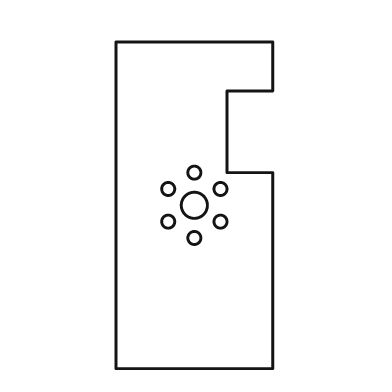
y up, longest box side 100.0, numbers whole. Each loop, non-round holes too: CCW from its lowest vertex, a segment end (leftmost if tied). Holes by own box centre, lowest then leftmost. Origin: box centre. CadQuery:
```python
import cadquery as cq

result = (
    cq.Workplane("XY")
    .moveTo(-24.0, -50.0)
    .lineTo(24.0, -50.0)
    .lineTo(24.0, 10.0)
    .lineTo(10.0, 10.0)
    .lineTo(10.0, 35.0)
    .lineTo(24.0, 35.0)
    .lineTo(24.0, 50.0)
    .lineTo(-24.0, 50.0)
    .close()
    .moveTo(0.0, -10.0)
    .circle(2.0)
    .moveTo(-8.0, -5.0)
    .circle(2.0)
    .moveTo(8.0, -5.0)
    .circle(2.0)
    .moveTo(0.0, 0.0)
    .circle(4.0)
    .moveTo(-8.0, 5.0)
    .circle(2.0)
    .moveTo(8.0, 5.0)
    .circle(2.0)
    .moveTo(0.0, 10.0)
    .circle(2.0)
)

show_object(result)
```